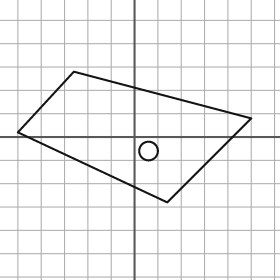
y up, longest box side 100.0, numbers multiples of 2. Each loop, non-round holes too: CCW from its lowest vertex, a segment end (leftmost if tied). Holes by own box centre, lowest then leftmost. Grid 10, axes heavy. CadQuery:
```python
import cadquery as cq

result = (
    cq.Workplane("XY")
    .moveTo(14.0, -28.0)
    .lineTo(50.0, 8.0)
    .lineTo(-26.0, 28.0)
    .lineTo(-50.0, 2.0)
    .close()
    .moveTo(6.0, -6.0)
    .circle(4.0)
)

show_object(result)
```